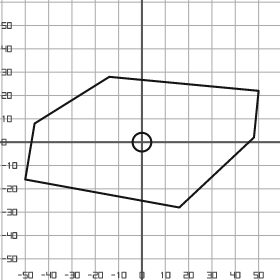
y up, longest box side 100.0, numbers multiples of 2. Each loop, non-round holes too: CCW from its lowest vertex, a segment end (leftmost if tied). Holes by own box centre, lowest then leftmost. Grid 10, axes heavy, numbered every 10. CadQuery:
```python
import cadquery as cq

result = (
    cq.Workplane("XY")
    .moveTo(16.0, -28.0)
    .lineTo(48.0, 2.0)
    .lineTo(50.0, 22.0)
    .lineTo(-14.0, 28.0)
    .lineTo(-46.0, 8.0)
    .lineTo(-50.0, -16.0)
    .close()
    .moveTo(0.0, 0.0)
    .circle(4.0)
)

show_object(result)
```